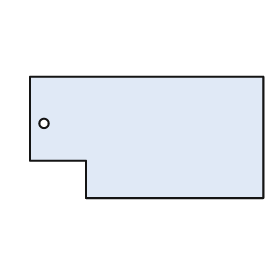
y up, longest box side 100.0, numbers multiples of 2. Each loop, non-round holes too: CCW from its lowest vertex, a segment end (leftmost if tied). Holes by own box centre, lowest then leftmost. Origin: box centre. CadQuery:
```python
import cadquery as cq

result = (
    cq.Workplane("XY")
    .moveTo(-26.0, -26.0)
    .lineTo(50.0, -26.0)
    .lineTo(50.0, 26.0)
    .lineTo(-50.0, 26.0)
    .lineTo(-50.0, -10.0)
    .lineTo(-26.0, -10.0)
    .close()
    .moveTo(-44.0, 6.0)
    .circle(2.0)
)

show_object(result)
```